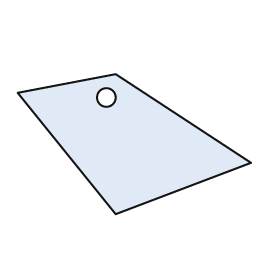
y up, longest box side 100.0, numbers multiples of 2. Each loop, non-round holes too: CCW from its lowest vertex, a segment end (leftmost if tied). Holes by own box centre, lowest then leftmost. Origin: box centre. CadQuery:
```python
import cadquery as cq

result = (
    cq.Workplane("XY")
    .moveTo(-8.0, -30.0)
    .lineTo(50.0, -8.0)
    .lineTo(-8.0, 30.0)
    .lineTo(-50.0, 22.0)
    .close()
    .moveTo(-12.0, 20.0)
    .circle(4.0)
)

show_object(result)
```